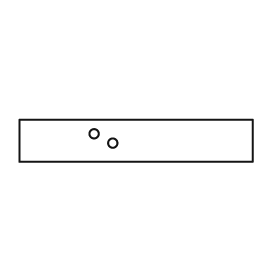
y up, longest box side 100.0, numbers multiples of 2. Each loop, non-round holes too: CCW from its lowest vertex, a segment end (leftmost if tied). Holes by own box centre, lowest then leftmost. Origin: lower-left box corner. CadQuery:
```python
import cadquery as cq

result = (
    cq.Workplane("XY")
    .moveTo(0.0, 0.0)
    .lineTo(100.0, 0.0)
    .lineTo(100.0, 18.0)
    .lineTo(0.0, 18.0)
    .close()
    .moveTo(40.0, 8.0)
    .circle(2.0)
    .moveTo(32.0, 12.0)
    .circle(2.0)
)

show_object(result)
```